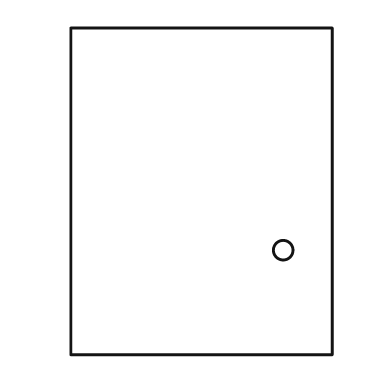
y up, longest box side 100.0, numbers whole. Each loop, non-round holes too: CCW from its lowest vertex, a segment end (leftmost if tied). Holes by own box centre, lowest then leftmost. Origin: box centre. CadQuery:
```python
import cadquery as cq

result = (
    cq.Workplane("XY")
    .moveTo(-40.0, -50.0)
    .lineTo(40.0, -50.0)
    .lineTo(40.0, 50.0)
    .lineTo(-40.0, 50.0)
    .close()
    .moveTo(25.0, -18.0)
    .circle(3.0)
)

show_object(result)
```